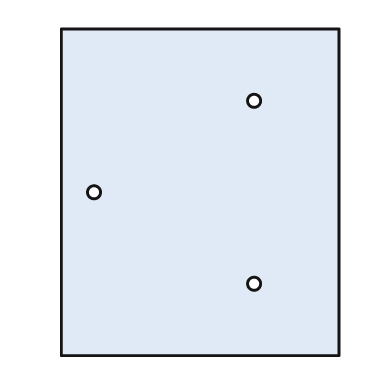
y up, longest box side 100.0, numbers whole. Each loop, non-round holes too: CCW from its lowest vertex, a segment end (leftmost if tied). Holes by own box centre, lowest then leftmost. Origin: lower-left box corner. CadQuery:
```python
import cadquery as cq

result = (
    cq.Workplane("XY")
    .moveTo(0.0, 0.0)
    .lineTo(85.0, 0.0)
    .lineTo(85.0, 100.0)
    .lineTo(0.0, 100.0)
    .close()
    .moveTo(59.0, 22.0)
    .circle(2.0)
    .moveTo(10.0, 50.0)
    .circle(2.0)
    .moveTo(59.0, 78.0)
    .circle(2.0)
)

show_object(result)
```